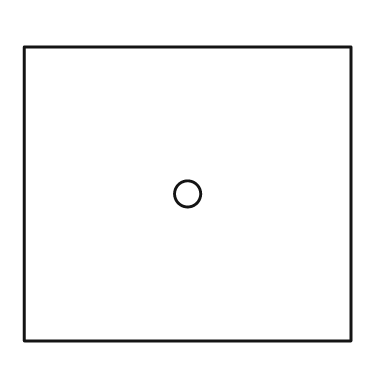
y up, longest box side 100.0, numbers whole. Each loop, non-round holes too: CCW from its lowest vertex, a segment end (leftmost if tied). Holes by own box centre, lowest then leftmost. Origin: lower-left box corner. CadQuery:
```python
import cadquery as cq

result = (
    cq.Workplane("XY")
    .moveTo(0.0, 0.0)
    .lineTo(100.0, 0.0)
    .lineTo(100.0, 90.0)
    .lineTo(0.0, 90.0)
    .close()
    .moveTo(50.0, 45.0)
    .circle(4.0)
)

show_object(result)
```